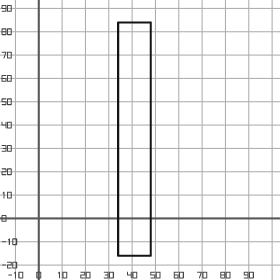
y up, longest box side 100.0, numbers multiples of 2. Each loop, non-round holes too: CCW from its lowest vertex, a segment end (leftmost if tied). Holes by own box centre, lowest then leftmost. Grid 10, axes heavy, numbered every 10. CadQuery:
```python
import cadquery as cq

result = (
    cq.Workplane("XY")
    .moveTo(34.0, -16.0)
    .lineTo(48.0, -16.0)
    .lineTo(48.0, 84.0)
    .lineTo(34.0, 84.0)
    .close()
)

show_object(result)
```